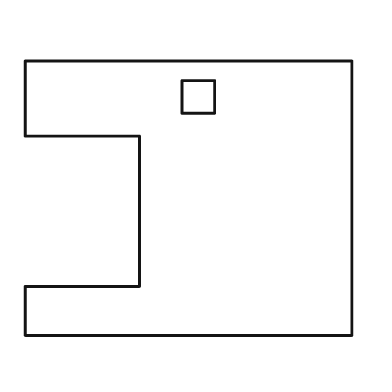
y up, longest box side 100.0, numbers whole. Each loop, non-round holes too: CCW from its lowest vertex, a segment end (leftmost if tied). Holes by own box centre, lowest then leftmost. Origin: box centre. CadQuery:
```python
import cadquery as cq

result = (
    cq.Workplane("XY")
    .moveTo(-50.0, -42.0)
    .lineTo(50.0, -42.0)
    .lineTo(50.0, 42.0)
    .lineTo(-50.0, 42.0)
    .lineTo(-50.0, 19.0)
    .lineTo(-15.0, 19.0)
    .lineTo(-15.0, -27.0)
    .lineTo(-50.0, -27.0)
    .close()
    .moveTo(-2.0, 26.0)
    .lineTo(8.0, 26.0)
    .lineTo(8.0, 36.0)
    .lineTo(-2.0, 36.0)
    .close()
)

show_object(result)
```